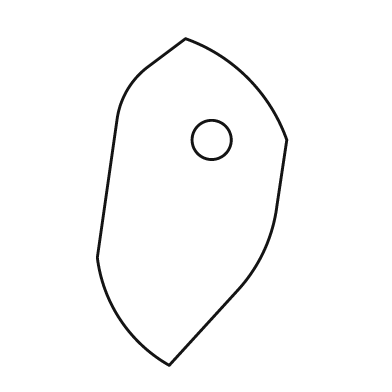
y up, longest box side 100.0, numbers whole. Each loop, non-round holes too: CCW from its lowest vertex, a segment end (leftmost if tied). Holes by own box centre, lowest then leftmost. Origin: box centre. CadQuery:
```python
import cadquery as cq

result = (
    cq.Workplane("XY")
    .moveTo(-7.0, -50.0)
    .lineTo(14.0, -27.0)
    .threePointArc((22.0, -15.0), (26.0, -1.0))
    .lineTo(29.0, 19.0)
    .threePointArc((17.0, 38.0), (-2.0, 50.0))
    .lineTo(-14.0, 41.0)
    .threePointArc((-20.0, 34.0), (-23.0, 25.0))
    .lineTo(-29.0, -17.0)
    .threePointArc((-22.0, -36.0), (-7.0, -50.0))
    .close()
    .moveTo(6.0, 19.0)
    .circle(6.0)
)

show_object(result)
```